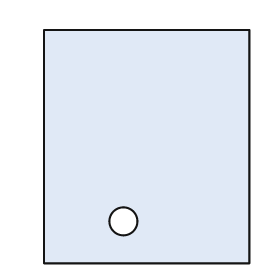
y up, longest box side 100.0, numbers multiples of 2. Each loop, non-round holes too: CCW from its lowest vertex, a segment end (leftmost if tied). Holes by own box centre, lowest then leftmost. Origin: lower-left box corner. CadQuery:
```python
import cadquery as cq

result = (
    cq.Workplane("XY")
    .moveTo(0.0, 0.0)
    .lineTo(88.0, 0.0)
    .lineTo(88.0, 100.0)
    .lineTo(0.0, 100.0)
    .close()
    .moveTo(34.0, 18.0)
    .circle(6.0)
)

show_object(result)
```